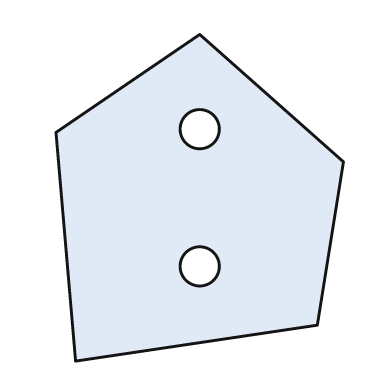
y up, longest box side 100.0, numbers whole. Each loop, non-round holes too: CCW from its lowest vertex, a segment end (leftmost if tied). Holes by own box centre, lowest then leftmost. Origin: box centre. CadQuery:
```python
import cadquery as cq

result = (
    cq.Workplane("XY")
    .moveTo(-38.0, -50.0)
    .lineTo(36.0, -39.0)
    .lineTo(44.0, 11.0)
    .lineTo(0.0, 50.0)
    .lineTo(-44.0, 20.0)
    .close()
    .moveTo(0.0, -21.0)
    .circle(6.0)
    .moveTo(0.0, 21.0)
    .circle(6.0)
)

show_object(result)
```